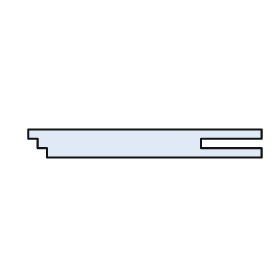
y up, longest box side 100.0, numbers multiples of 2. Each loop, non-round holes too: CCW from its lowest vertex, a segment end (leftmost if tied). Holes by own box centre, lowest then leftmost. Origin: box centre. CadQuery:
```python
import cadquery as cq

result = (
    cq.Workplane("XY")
    .moveTo(-42.0, -6.0)
    .lineTo(50.0, -6.0)
    .lineTo(50.0, -2.0)
    .lineTo(24.0, -2.0)
    .lineTo(24.0, 2.0)
    .lineTo(50.0, 2.0)
    .lineTo(50.0, 6.0)
    .lineTo(-50.0, 6.0)
    .lineTo(-50.0, 2.0)
    .lineTo(-46.0, 2.0)
    .lineTo(-46.0, -2.0)
    .lineTo(-42.0, -2.0)
    .close()
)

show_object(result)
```